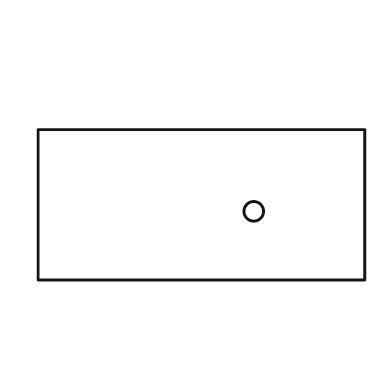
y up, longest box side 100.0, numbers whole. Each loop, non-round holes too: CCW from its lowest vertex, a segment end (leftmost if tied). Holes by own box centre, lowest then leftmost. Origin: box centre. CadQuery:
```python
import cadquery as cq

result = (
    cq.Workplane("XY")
    .moveTo(-50.0, -23.0)
    .lineTo(50.0, -23.0)
    .lineTo(50.0, 23.0)
    .lineTo(-50.0, 23.0)
    .close()
    .moveTo(16.0, -2.0)
    .circle(3.0)
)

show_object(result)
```